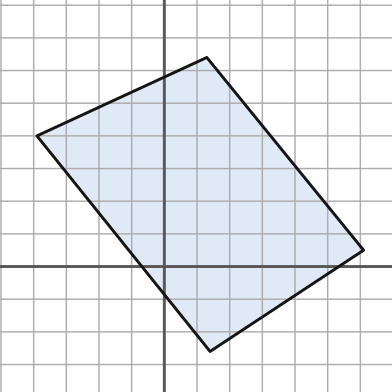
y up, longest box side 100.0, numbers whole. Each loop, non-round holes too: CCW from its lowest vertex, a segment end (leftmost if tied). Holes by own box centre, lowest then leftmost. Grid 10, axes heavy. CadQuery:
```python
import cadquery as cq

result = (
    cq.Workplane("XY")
    .moveTo(14.0, -26.0)
    .lineTo(61.0, 5.0)
    .lineTo(13.0, 64.0)
    .lineTo(-39.0, 40.0)
    .close()
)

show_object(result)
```